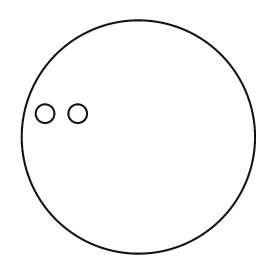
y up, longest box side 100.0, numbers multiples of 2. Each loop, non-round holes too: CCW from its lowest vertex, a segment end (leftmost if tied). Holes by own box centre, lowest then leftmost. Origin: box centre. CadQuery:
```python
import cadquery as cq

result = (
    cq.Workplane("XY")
    .moveTo(0.0, 0.0)
    .circle(50.0)
    .moveTo(-40.0, 10.0)
    .circle(4.0)
    .moveTo(-26.0, 10.0)
    .circle(4.0)
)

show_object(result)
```